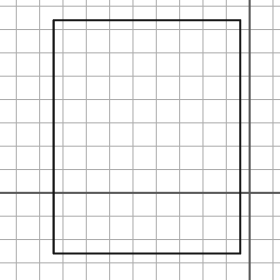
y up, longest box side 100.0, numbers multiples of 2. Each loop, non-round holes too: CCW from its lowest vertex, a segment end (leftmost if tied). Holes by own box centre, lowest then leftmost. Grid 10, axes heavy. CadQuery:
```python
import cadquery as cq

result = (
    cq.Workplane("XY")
    .moveTo(-84.0, -26.0)
    .lineTo(-4.0, -26.0)
    .lineTo(-4.0, 74.0)
    .lineTo(-84.0, 74.0)
    .close()
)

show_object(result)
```